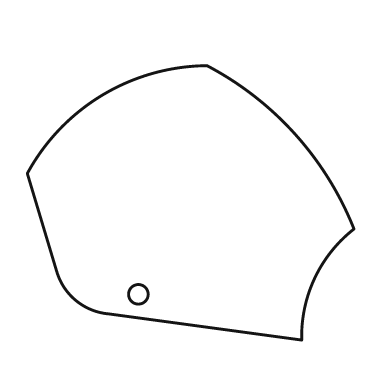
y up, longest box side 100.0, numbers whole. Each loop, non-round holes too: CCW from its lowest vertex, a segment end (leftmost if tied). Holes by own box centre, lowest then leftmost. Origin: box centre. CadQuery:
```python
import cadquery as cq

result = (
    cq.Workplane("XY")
    .moveTo(34.0, -42.0)
    .threePointArc((38.0, -23.0), (50.0, -8.0))
    .threePointArc((32.0, 21.0), (5.0, 42.0))
    .threePointArc((-27.0, 33.0), (-50.0, 9.0))
    .lineTo(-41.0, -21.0)
    .threePointArc((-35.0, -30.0), (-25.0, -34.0))
    .close()
    .moveTo(-16.0, -28.0)
    .circle(3.0)
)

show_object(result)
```